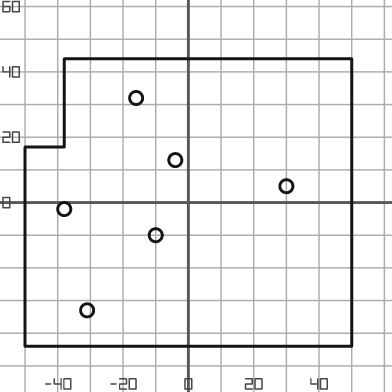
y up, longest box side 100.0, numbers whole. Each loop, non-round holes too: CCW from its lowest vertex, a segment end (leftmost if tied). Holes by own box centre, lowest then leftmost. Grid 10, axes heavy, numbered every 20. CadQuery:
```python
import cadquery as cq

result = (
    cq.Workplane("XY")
    .moveTo(-50.0, -44.0)
    .lineTo(50.0, -44.0)
    .lineTo(50.0, 44.0)
    .lineTo(-38.0, 44.0)
    .lineTo(-38.0, 17.0)
    .lineTo(-50.0, 17.0)
    .close()
    .moveTo(-31.0, -33.0)
    .circle(2.0)
    .moveTo(-10.0, -10.0)
    .circle(2.0)
    .moveTo(-38.0, -2.0)
    .circle(2.0)
    .moveTo(30.0, 5.0)
    .circle(2.0)
    .moveTo(-4.0, 13.0)
    .circle(2.0)
    .moveTo(-16.0, 32.0)
    .circle(2.0)
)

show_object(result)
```